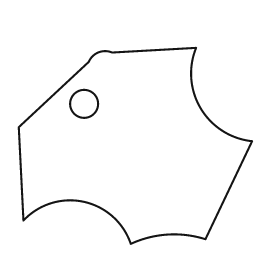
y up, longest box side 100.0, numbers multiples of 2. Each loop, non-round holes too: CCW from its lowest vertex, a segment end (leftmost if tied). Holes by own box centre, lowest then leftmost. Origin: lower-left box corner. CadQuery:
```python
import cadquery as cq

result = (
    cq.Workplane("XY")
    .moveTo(48.0, 0.0)
    .threePointArc((64.0, 4.0), (80.0, 2.0))
    .lineTo(100.0, 44.0)
    .threePointArc((78.0, 58.0), (76.0, 84.0))
    .lineTo(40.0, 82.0)
    .threePointArc((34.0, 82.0), (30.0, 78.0))
    .lineTo(0.0, 50.0)
    .lineTo(2.0, 10.0)
    .threePointArc((28.0, 18.0), (48.0, 0.0))
    .close()
    .moveTo(28.0, 60.0)
    .circle(6.0)
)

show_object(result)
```